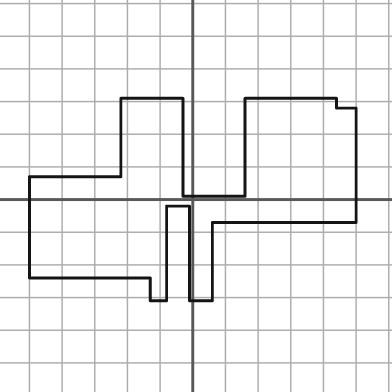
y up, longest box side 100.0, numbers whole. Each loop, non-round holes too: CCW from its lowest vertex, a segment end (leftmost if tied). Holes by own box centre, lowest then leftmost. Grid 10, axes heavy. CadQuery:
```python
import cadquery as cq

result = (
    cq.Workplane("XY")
    .moveTo(-13.0, -31.0)
    .lineTo(-8.0, -31.0)
    .lineTo(-8.0, -2.0)
    .lineTo(-1.0, -2.0)
    .lineTo(-1.0, -31.0)
    .lineTo(6.0, -31.0)
    .lineTo(6.0, -7.0)
    .lineTo(50.0, -7.0)
    .lineTo(50.0, 28.0)
    .lineTo(44.0, 28.0)
    .lineTo(44.0, 31.0)
    .lineTo(16.0, 31.0)
    .lineTo(16.0, 1.0)
    .lineTo(-3.0, 1.0)
    .lineTo(-3.0, 31.0)
    .lineTo(-22.0, 31.0)
    .lineTo(-22.0, 7.0)
    .lineTo(-50.0, 7.0)
    .lineTo(-50.0, -24.0)
    .lineTo(-13.0, -24.0)
    .close()
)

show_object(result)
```